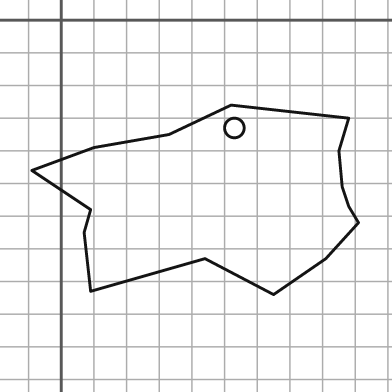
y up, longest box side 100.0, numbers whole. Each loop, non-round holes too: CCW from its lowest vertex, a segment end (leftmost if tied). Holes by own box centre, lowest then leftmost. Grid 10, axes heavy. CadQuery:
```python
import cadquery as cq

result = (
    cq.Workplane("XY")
    .moveTo(65.0, -84.0)
    .lineTo(81.0, -73.0)
    .lineTo(91.0, -62.0)
    .lineTo(88.0, -57.0)
    .lineTo(86.0, -51.0)
    .lineTo(85.0, -40.0)
    .lineTo(88.0, -30.0)
    .lineTo(52.0, -26.0)
    .lineTo(33.0, -35.0)
    .lineTo(10.0, -39.0)
    .lineTo(-9.0, -46.0)
    .lineTo(9.0, -58.0)
    .lineTo(7.0, -65.0)
    .lineTo(9.0, -83.0)
    .lineTo(44.0, -73.0)
    .close()
    .moveTo(53.0, -33.0)
    .circle(3.0)
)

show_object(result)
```